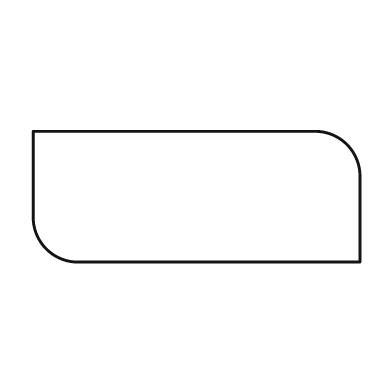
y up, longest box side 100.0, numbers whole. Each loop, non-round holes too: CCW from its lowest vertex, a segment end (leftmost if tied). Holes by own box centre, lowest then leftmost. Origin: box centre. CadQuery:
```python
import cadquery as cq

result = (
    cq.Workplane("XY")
    .moveTo(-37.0, -20.0)
    .lineTo(50.0, -20.0)
    .lineTo(50.0, 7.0)
    .threePointArc((46.0, 16.0), (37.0, 20.0))
    .lineTo(-50.0, 20.0)
    .lineTo(-50.0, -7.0)
    .threePointArc((-46.0, -16.0), (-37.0, -20.0))
    .close()
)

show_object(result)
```